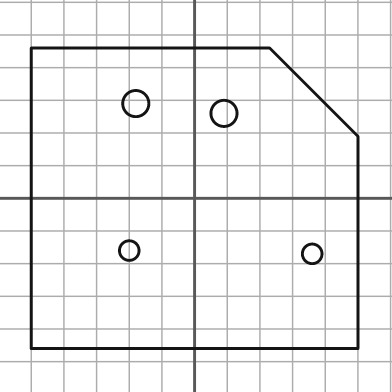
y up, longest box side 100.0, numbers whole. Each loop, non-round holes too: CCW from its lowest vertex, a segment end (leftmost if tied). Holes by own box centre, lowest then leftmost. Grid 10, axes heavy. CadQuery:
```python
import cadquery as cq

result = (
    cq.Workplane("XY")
    .moveTo(-50.0, -46.0)
    .lineTo(50.0, -46.0)
    .lineTo(50.0, 19.0)
    .lineTo(23.0, 46.0)
    .lineTo(-50.0, 46.0)
    .close()
    .moveTo(36.0, -17.0)
    .circle(3.0)
    .moveTo(-20.0, -16.0)
    .circle(3.0)
    .moveTo(9.0, 26.0)
    .circle(4.0)
    .moveTo(-18.0, 29.0)
    .circle(4.0)
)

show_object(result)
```